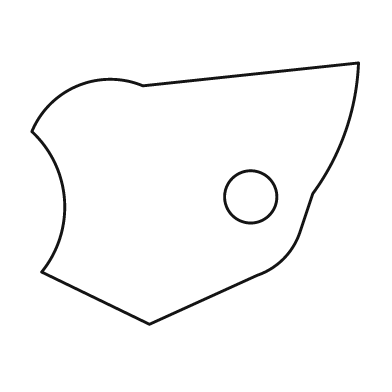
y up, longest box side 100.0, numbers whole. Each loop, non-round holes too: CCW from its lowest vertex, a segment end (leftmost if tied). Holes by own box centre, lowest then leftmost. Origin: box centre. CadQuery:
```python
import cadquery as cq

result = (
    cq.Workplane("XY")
    .moveTo(-14.0, -40.0)
    .lineTo(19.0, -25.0)
    .threePointArc((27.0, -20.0), (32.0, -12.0))
    .lineTo(36.0, 0.0)
    .threePointArc((46.0, 19.0), (50.0, 40.0))
    .lineTo(-16.0, 33.0)
    .threePointArc((-36.0, 33.0), (-50.0, 19.0))
    .threePointArc((-40.0, -2.0), (-47.0, -24.0))
    .close()
    .moveTo(17.0, -1.0)
    .circle(8.0)
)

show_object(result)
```